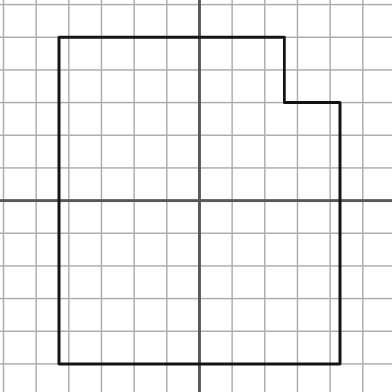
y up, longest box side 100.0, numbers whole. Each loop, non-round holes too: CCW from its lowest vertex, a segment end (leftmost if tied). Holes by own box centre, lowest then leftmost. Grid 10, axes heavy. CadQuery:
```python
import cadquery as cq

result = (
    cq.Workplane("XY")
    .moveTo(-43.0, -50.0)
    .lineTo(43.0, -50.0)
    .lineTo(43.0, 30.0)
    .lineTo(26.0, 30.0)
    .lineTo(26.0, 50.0)
    .lineTo(-43.0, 50.0)
    .close()
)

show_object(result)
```